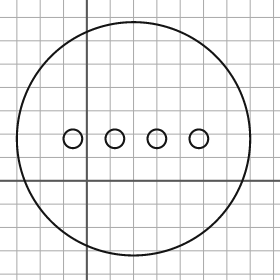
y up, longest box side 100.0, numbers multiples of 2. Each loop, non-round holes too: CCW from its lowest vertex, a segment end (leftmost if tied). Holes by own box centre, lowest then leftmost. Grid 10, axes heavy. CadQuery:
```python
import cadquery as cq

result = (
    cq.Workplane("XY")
    .moveTo(20.0, 18.0)
    .circle(50.0)
    .moveTo(-6.0, 18.0)
    .circle(4.0)
    .moveTo(12.0, 18.0)
    .circle(4.0)
    .moveTo(30.0, 18.0)
    .circle(4.0)
    .moveTo(48.0, 18.0)
    .circle(4.0)
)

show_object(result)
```